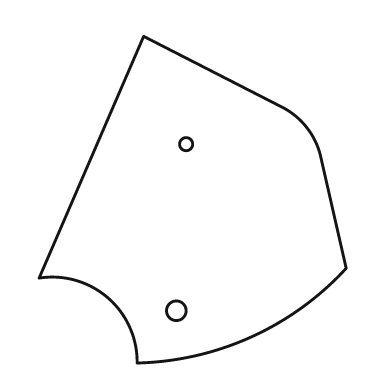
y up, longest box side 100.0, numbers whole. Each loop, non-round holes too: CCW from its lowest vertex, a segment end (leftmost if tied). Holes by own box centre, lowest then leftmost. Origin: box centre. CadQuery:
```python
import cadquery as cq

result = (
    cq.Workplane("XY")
    .moveTo(-17.0, -50.0)
    .threePointArc((18.0, -42.0), (47.0, -21.0))
    .lineTo(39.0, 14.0)
    .threePointArc((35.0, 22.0), (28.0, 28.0))
    .lineTo(-15.0, 50.0)
    .lineTo(-47.0, -24.0)
    .threePointArc((-26.0, -30.0), (-17.0, -50.0))
    .close()
    .moveTo(-5.0, -34.0)
    .circle(3.0)
    .moveTo(-2.0, 17.0)
    .circle(2.0)
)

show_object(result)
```